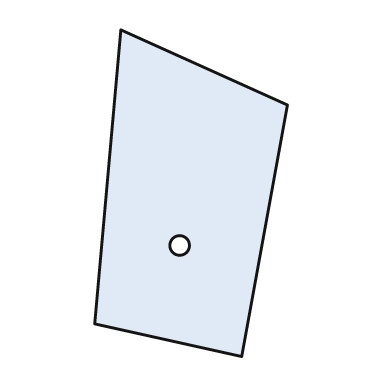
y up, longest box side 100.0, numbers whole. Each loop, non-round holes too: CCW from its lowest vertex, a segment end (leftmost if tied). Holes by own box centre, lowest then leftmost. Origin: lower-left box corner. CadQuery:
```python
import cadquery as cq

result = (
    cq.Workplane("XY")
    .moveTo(45.0, 0.0)
    .lineTo(59.0, 77.0)
    .lineTo(8.0, 100.0)
    .lineTo(0.0, 10.0)
    .close()
    .moveTo(26.0, 34.0)
    .circle(3.0)
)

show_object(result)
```